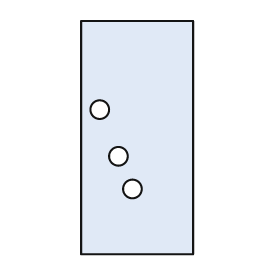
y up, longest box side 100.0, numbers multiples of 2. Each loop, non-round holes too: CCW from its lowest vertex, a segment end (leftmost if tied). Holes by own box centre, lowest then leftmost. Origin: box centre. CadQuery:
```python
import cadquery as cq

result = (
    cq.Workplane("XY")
    .moveTo(-24.0, -50.0)
    .lineTo(24.0, -50.0)
    .lineTo(24.0, 50.0)
    .lineTo(-24.0, 50.0)
    .close()
    .moveTo(-2.0, -22.0)
    .circle(4.0)
    .moveTo(-8.0, -8.0)
    .circle(4.0)
    .moveTo(-16.0, 12.0)
    .circle(4.0)
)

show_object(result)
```